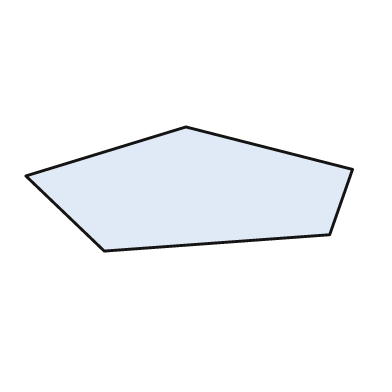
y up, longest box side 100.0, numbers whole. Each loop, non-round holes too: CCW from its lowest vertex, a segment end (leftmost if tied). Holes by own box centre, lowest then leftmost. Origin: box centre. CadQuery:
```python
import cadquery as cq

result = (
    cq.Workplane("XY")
    .moveTo(-26.0, -19.0)
    .lineTo(43.0, -14.0)
    .lineTo(50.0, 6.0)
    .lineTo(-1.0, 19.0)
    .lineTo(-50.0, 4.0)
    .close()
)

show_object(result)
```